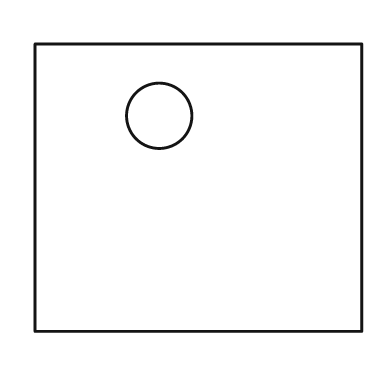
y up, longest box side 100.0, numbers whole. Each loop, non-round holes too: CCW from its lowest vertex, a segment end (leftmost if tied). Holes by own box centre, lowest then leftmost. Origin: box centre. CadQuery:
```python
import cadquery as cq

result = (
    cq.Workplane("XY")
    .moveTo(-50.0, -44.0)
    .lineTo(50.0, -44.0)
    .lineTo(50.0, 44.0)
    .lineTo(-50.0, 44.0)
    .close()
    .moveTo(-12.0, 22.0)
    .circle(10.0)
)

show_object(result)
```